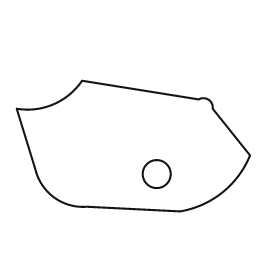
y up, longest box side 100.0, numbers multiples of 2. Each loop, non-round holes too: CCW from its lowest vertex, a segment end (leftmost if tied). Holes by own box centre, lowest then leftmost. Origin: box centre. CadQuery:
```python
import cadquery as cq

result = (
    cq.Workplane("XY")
    .moveTo(20.0, -28.0)
    .threePointArc((38.0, -20.0), (50.0, -4.0))
    .lineTo(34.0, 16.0)
    .threePointArc((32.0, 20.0), (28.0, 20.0))
    .lineTo(-22.0, 28.0)
    .threePointArc((-34.0, 18.0), (-50.0, 16.0))
    .lineTo(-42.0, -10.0)
    .threePointArc((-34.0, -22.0), (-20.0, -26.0))
    .close()
    .moveTo(10.0, -12.0)
    .circle(6.0)
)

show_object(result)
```